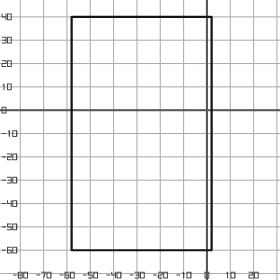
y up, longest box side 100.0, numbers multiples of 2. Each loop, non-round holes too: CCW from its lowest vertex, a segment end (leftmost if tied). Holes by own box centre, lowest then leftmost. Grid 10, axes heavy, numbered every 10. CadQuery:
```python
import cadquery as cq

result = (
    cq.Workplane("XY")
    .moveTo(-58.0, -60.0)
    .lineTo(2.0, -60.0)
    .lineTo(2.0, 40.0)
    .lineTo(-58.0, 40.0)
    .close()
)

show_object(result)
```